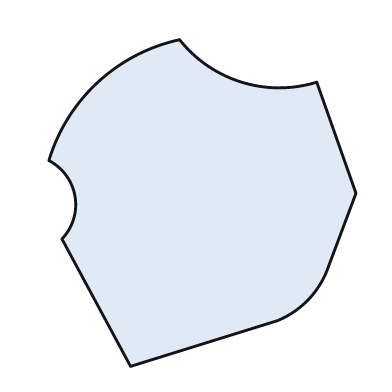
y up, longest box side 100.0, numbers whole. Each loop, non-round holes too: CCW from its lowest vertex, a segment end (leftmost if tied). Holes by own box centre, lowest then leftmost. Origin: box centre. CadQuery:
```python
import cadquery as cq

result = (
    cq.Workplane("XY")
    .moveTo(-22.0, -50.0)
    .lineTo(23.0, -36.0)
    .threePointArc((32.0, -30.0), (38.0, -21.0))
    .lineTo(47.0, 3.0)
    .lineTo(35.0, 37.0)
    .threePointArc((12.0, 37.0), (-7.0, 50.0))
    .threePointArc((-32.0, 37.0), (-47.0, 13.0))
    .threePointArc((-39.0, 2.0), (-43.0, -11.0))
    .close()
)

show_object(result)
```